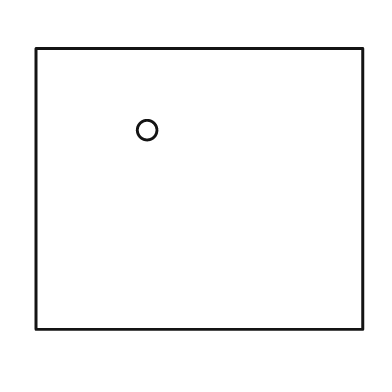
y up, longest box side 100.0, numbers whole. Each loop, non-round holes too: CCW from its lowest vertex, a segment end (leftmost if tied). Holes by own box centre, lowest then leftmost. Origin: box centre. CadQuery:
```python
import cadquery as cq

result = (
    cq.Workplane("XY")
    .moveTo(-50.0, -43.0)
    .lineTo(50.0, -43.0)
    .lineTo(50.0, 43.0)
    .lineTo(-50.0, 43.0)
    .close()
    .moveTo(-16.0, 18.0)
    .circle(3.0)
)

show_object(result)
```